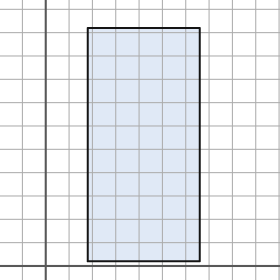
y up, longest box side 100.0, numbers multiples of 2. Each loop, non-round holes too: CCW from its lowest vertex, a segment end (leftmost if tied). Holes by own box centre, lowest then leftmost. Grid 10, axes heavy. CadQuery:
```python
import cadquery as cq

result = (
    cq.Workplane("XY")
    .moveTo(18.0, 2.0)
    .lineTo(66.0, 2.0)
    .lineTo(66.0, 102.0)
    .lineTo(18.0, 102.0)
    .close()
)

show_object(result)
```